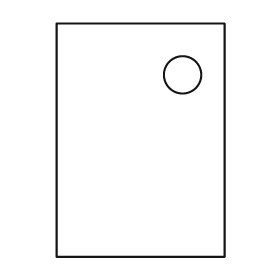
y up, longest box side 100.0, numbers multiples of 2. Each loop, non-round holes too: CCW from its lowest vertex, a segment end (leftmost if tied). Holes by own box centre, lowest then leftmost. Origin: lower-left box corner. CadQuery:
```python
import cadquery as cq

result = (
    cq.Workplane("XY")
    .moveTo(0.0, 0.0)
    .lineTo(72.0, 0.0)
    .lineTo(72.0, 100.0)
    .lineTo(0.0, 100.0)
    .close()
    .moveTo(54.0, 78.0)
    .circle(8.0)
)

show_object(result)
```